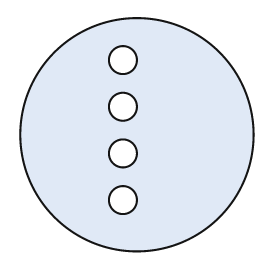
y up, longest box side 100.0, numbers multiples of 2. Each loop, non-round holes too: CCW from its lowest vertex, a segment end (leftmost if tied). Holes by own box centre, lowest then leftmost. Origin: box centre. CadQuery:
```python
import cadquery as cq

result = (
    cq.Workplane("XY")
    .moveTo(0.0, 0.0)
    .circle(50.0)
    .moveTo(-6.0, -28.0)
    .circle(6.0)
    .moveTo(-6.0, -8.0)
    .circle(6.0)
    .moveTo(-6.0, 12.0)
    .circle(6.0)
    .moveTo(-6.0, 32.0)
    .circle(6.0)
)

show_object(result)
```